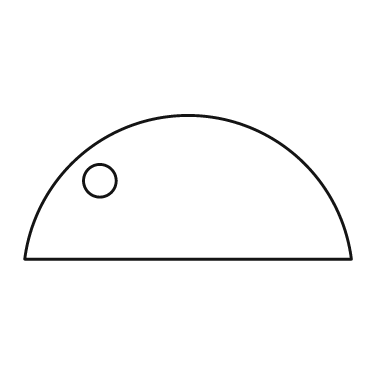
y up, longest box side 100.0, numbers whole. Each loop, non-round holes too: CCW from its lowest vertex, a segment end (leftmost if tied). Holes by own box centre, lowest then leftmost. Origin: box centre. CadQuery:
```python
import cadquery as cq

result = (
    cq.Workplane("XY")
    .moveTo(-50.0, -22.0)
    .lineTo(50.0, -22.0)
    .threePointArc((0.0, 22.0), (-50.0, -22.0))
    .close()
    .moveTo(-27.0, 2.0)
    .circle(5.0)
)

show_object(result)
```